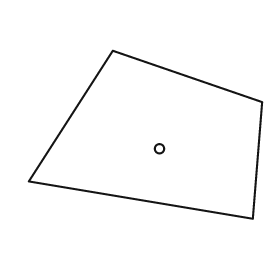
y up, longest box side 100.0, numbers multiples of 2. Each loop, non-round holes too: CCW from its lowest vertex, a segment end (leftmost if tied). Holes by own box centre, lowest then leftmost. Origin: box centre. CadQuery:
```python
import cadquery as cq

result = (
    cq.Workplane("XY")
    .moveTo(46.0, -36.0)
    .lineTo(50.0, 14.0)
    .lineTo(-14.0, 36.0)
    .lineTo(-50.0, -20.0)
    .close()
    .moveTo(6.0, -6.0)
    .circle(2.0)
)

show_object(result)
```